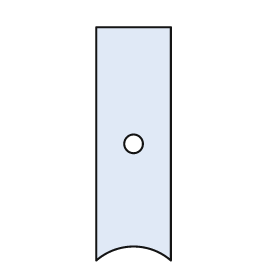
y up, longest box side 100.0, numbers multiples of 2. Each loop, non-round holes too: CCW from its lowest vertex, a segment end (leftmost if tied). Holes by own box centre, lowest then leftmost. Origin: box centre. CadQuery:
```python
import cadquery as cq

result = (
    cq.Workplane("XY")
    .moveTo(-16.0, -50.0)
    .threePointArc((0.0, -44.0), (16.0, -50.0))
    .lineTo(16.0, 50.0)
    .lineTo(-16.0, 50.0)
    .close()
    .moveTo(0.0, 0.0)
    .circle(4.0)
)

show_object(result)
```